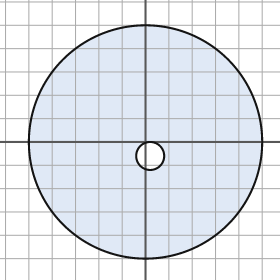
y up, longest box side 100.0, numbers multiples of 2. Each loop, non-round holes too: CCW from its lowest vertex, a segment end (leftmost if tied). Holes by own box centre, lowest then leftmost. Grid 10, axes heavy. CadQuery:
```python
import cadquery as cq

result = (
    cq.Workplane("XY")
    .moveTo(0.0, 0.0)
    .circle(50.0)
    .moveTo(2.0, -6.0)
    .circle(6.0)
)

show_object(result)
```